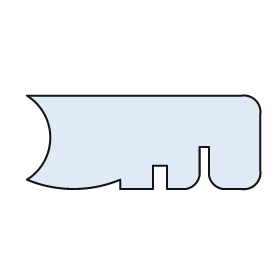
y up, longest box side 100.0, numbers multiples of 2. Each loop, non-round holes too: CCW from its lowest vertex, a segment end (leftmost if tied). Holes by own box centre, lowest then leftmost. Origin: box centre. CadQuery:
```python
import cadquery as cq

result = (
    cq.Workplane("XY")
    .moveTo(-10.0, -20.0)
    .lineTo(4.0, -20.0)
    .lineTo(4.0, -10.0)
    .lineTo(10.0, -10.0)
    .lineTo(10.0, -20.0)
    .lineTo(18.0, -20.0)
    .threePointArc((22.0, -18.0), (24.0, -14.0))
    .lineTo(24.0, -2.0)
    .lineTo(28.0, -2.0)
    .lineTo(28.0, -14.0)
    .threePointArc((30.0, -18.0), (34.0, -20.0))
    .lineTo(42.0, -20.0)
    .threePointArc((48.0, -18.0), (50.0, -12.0))
    .lineTo(50.0, 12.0)
    .threePointArc((48.0, 18.0), (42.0, 20.0))
    .lineTo(-50.0, 20.0)
    .threePointArc((-40.0, 2.0), (-50.0, -16.0))
    .threePointArc((-30.0, -20.0), (-10.0, -16.0))
    .close()
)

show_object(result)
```